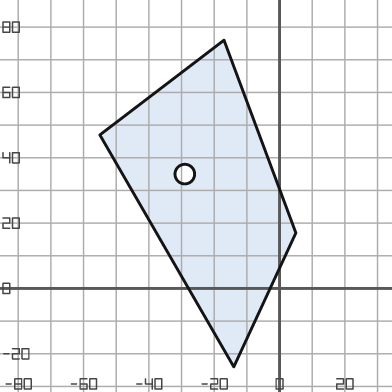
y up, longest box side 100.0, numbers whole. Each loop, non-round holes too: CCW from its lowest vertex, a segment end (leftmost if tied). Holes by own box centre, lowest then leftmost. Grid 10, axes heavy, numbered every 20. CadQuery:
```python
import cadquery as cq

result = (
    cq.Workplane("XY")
    .moveTo(-14.0, -24.0)
    .lineTo(5.0, 17.0)
    .lineTo(-17.0, 76.0)
    .lineTo(-55.0, 47.0)
    .close()
    .moveTo(-29.0, 35.0)
    .circle(3.0)
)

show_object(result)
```